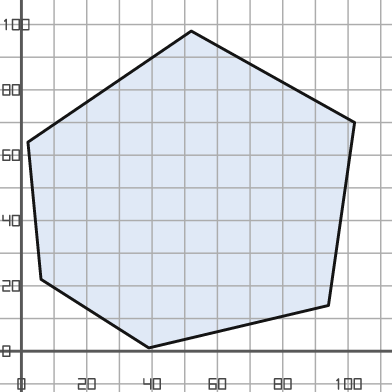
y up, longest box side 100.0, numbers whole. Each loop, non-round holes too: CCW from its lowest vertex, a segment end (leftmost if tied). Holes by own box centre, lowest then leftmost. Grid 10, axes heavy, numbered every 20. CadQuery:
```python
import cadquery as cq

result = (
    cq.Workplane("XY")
    .moveTo(39.0, 1.0)
    .lineTo(94.0, 14.0)
    .lineTo(102.0, 70.0)
    .lineTo(52.0, 98.0)
    .lineTo(2.0, 64.0)
    .lineTo(6.0, 22.0)
    .close()
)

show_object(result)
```